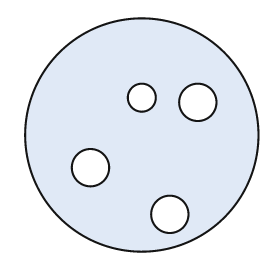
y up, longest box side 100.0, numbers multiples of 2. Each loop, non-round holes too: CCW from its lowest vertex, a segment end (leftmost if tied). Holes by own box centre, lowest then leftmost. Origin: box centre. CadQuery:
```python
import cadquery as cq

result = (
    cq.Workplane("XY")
    .moveTo(0.0, 0.0)
    .circle(50.0)
    .moveTo(12.0, -34.0)
    .circle(8.0)
    .moveTo(-22.0, -14.0)
    .circle(8.0)
    .moveTo(24.0, 14.0)
    .circle(8.0)
    .moveTo(0.0, 16.0)
    .circle(6.0)
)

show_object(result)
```